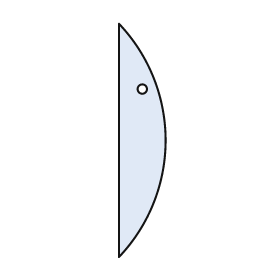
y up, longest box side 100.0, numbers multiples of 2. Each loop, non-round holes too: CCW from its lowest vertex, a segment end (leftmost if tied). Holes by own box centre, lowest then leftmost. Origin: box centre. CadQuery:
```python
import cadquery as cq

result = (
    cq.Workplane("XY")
    .moveTo(-10.0, -50.0)
    .threePointArc((10.0, 0.0), (-10.0, 50.0))
    .close()
    .moveTo(0.0, 22.0)
    .circle(2.0)
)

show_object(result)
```